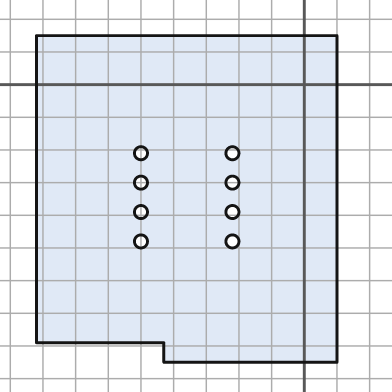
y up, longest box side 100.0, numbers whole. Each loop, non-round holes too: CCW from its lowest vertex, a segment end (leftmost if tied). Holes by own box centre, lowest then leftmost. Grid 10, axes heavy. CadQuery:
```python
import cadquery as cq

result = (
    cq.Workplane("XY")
    .moveTo(-43.0, -85.0)
    .lineTo(10.0, -85.0)
    .lineTo(10.0, 15.0)
    .lineTo(-82.0, 15.0)
    .lineTo(-82.0, -79.0)
    .lineTo(-43.0, -79.0)
    .close()
    .moveTo(-50.0, -48.0)
    .circle(2.0)
    .moveTo(-22.0, -48.0)
    .circle(2.0)
    .moveTo(-50.0, -39.0)
    .circle(2.0)
    .moveTo(-22.0, -39.0)
    .circle(2.0)
    .moveTo(-50.0, -30.0)
    .circle(2.0)
    .moveTo(-22.0, -30.0)
    .circle(2.0)
    .moveTo(-50.0, -21.0)
    .circle(2.0)
    .moveTo(-22.0, -21.0)
    .circle(2.0)
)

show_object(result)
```